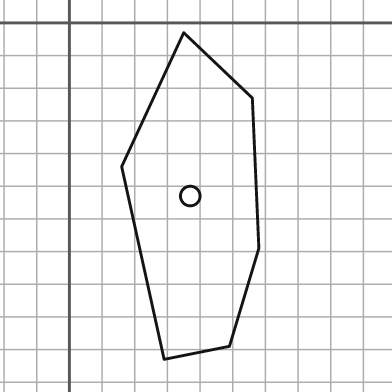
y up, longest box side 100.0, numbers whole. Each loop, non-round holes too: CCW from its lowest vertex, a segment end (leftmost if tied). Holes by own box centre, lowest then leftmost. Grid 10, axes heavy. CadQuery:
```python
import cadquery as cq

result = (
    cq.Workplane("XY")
    .moveTo(29.0, -103.0)
    .lineTo(49.0, -99.0)
    .lineTo(58.0, -69.0)
    .lineTo(56.0, -23.0)
    .lineTo(35.0, -3.0)
    .lineTo(16.0, -44.0)
    .close()
    .moveTo(37.0, -53.0)
    .circle(3.0)
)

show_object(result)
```